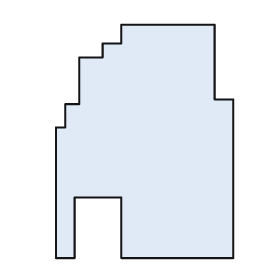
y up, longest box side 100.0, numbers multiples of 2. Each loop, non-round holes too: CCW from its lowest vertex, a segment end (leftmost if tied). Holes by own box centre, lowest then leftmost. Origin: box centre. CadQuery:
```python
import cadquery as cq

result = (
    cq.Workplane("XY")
    .moveTo(-38.0, -50.0)
    .lineTo(-30.0, -50.0)
    .lineTo(-30.0, -24.0)
    .lineTo(-10.0, -24.0)
    .lineTo(-10.0, -50.0)
    .lineTo(38.0, -50.0)
    .lineTo(38.0, 18.0)
    .lineTo(30.0, 18.0)
    .lineTo(30.0, 50.0)
    .lineTo(-10.0, 50.0)
    .lineTo(-10.0, 42.0)
    .lineTo(-18.0, 42.0)
    .lineTo(-18.0, 36.0)
    .lineTo(-28.0, 36.0)
    .lineTo(-28.0, 16.0)
    .lineTo(-34.0, 16.0)
    .lineTo(-34.0, 6.0)
    .lineTo(-38.0, 6.0)
    .close()
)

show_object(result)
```